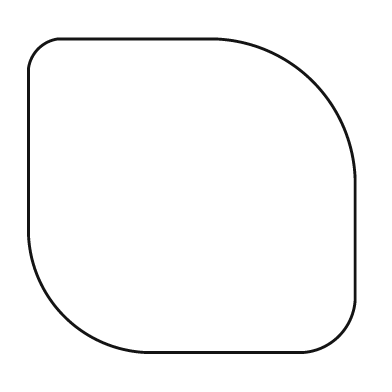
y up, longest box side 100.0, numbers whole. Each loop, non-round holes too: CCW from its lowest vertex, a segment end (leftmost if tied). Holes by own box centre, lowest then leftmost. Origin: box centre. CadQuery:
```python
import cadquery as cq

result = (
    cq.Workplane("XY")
    .moveTo(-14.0, -48.0)
    .lineTo(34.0, -48.0)
    .threePointArc((45.0, -43.0), (50.0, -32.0))
    .lineTo(50.0, 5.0)
    .threePointArc((37.0, 35.0), (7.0, 48.0))
    .lineTo(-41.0, 48.0)
    .threePointArc((-47.0, 45.0), (-50.0, 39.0))
    .lineTo(-50.0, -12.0)
    .threePointArc((-39.0, -37.0), (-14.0, -48.0))
    .close()
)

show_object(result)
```